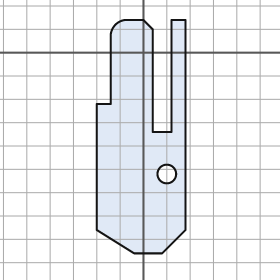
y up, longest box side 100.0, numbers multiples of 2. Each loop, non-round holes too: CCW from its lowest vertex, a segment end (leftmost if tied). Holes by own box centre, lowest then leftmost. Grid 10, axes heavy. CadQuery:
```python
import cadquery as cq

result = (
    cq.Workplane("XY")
    .moveTo(-4.0, -86.0)
    .lineTo(8.0, -86.0)
    .lineTo(18.0, -76.0)
    .lineTo(18.0, 14.0)
    .lineTo(12.0, 14.0)
    .lineTo(12.0, -34.0)
    .lineTo(4.0, -34.0)
    .lineTo(4.0, 10.0)
    .lineTo(0.0, 14.0)
    .lineTo(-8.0, 14.0)
    .threePointArc((-12.0, 12.0), (-14.0, 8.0))
    .lineTo(-14.0, -22.0)
    .lineTo(-20.0, -22.0)
    .lineTo(-20.0, -76.0)
    .close()
    .moveTo(10.0, -52.0)
    .circle(4.0)
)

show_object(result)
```